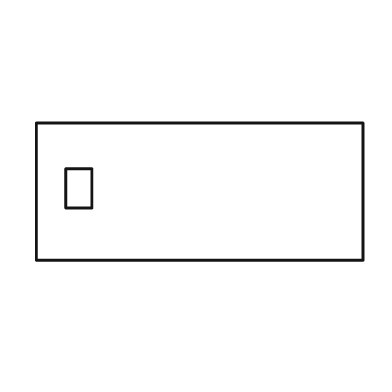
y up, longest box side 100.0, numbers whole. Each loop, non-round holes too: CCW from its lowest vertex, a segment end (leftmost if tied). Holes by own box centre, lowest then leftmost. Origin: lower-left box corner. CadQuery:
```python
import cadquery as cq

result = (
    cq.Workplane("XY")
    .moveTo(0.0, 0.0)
    .lineTo(100.0, 0.0)
    .lineTo(100.0, 42.0)
    .lineTo(0.0, 42.0)
    .close()
    .moveTo(9.0, 16.0)
    .lineTo(17.0, 16.0)
    .lineTo(17.0, 28.0)
    .lineTo(9.0, 28.0)
    .close()
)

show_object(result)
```